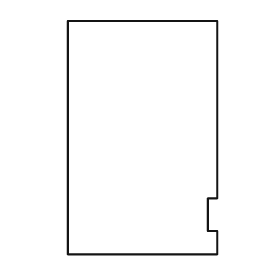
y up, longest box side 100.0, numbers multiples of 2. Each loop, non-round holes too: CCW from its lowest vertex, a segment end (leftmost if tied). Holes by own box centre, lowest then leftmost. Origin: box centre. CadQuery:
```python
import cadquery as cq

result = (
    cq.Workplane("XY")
    .moveTo(-32.0, -50.0)
    .lineTo(32.0, -50.0)
    .lineTo(32.0, -40.0)
    .lineTo(28.0, -40.0)
    .lineTo(28.0, -26.0)
    .lineTo(32.0, -26.0)
    .lineTo(32.0, 50.0)
    .lineTo(-32.0, 50.0)
    .close()
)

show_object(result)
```